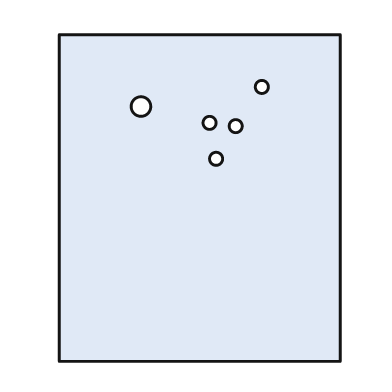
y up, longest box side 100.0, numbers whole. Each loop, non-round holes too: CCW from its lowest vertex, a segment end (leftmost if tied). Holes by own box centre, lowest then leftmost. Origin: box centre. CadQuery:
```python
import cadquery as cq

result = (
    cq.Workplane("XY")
    .moveTo(-43.0, -50.0)
    .lineTo(43.0, -50.0)
    .lineTo(43.0, 50.0)
    .lineTo(-43.0, 50.0)
    .close()
    .moveTo(5.0, 12.0)
    .circle(2.0)
    .moveTo(11.0, 22.0)
    .circle(2.0)
    .moveTo(3.0, 23.0)
    .circle(2.0)
    .moveTo(-18.0, 28.0)
    .circle(3.0)
    .moveTo(19.0, 34.0)
    .circle(2.0)
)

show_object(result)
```